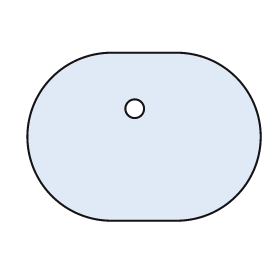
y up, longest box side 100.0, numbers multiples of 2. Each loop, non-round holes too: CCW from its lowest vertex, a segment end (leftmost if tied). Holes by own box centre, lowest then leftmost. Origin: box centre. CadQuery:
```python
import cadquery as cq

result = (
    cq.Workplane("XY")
    .moveTo(-14.0, -36.0)
    .lineTo(14.0, -36.0)
    .threePointArc((50.0, 0.0), (14.0, 36.0))
    .lineTo(-14.0, 36.0)
    .threePointArc((-50.0, 0.0), (-14.0, -36.0))
    .close()
    .moveTo(-4.0, 12.0)
    .circle(4.0)
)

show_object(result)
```